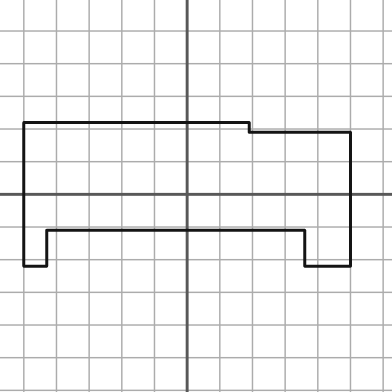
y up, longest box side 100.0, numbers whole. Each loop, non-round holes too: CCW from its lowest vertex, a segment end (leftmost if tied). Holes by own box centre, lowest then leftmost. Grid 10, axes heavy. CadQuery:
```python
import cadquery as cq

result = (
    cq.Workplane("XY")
    .moveTo(-50.0, -22.0)
    .lineTo(-43.0, -22.0)
    .lineTo(-43.0, -11.0)
    .lineTo(36.0, -11.0)
    .lineTo(36.0, -22.0)
    .lineTo(50.0, -22.0)
    .lineTo(50.0, 19.0)
    .lineTo(19.0, 19.0)
    .lineTo(19.0, 22.0)
    .lineTo(-50.0, 22.0)
    .close()
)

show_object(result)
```